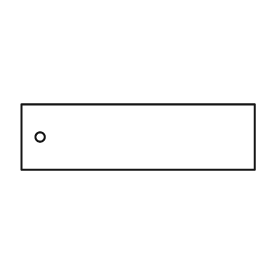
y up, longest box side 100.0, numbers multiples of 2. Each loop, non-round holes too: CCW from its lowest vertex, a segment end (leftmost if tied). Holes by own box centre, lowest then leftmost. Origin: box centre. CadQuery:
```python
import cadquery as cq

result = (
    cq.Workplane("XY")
    .moveTo(-50.0, -14.0)
    .lineTo(50.0, -14.0)
    .lineTo(50.0, 14.0)
    .lineTo(-50.0, 14.0)
    .close()
    .moveTo(-42.0, 0.0)
    .circle(2.0)
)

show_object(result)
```